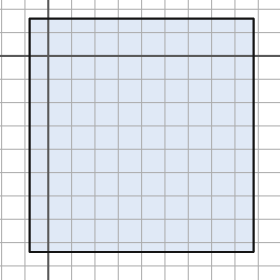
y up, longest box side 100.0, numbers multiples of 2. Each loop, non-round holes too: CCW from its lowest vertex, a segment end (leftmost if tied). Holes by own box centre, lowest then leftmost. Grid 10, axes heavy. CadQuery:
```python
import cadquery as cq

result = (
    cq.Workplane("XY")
    .moveTo(-8.0, -84.0)
    .lineTo(88.0, -84.0)
    .lineTo(88.0, 16.0)
    .lineTo(-8.0, 16.0)
    .close()
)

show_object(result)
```